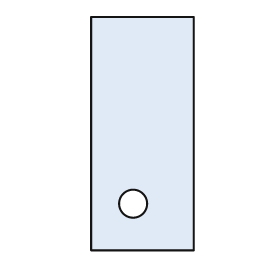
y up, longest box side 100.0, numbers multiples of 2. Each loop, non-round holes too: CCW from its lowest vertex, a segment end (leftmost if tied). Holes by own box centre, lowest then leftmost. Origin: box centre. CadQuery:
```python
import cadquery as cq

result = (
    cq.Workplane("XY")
    .moveTo(-22.0, -50.0)
    .lineTo(22.0, -50.0)
    .lineTo(22.0, 50.0)
    .lineTo(-22.0, 50.0)
    .close()
    .moveTo(-4.0, -30.0)
    .circle(6.0)
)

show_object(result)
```